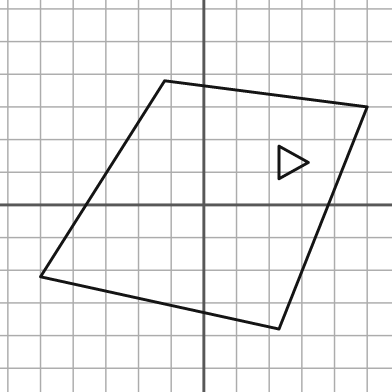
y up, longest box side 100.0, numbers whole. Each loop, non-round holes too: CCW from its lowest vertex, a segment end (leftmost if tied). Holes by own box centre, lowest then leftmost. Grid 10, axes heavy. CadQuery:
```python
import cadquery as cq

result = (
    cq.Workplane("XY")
    .moveTo(23.0, -38.0)
    .lineTo(50.0, 30.0)
    .lineTo(-12.0, 38.0)
    .lineTo(-50.0, -22.0)
    .close()
    .moveTo(23.0, 8.0)
    .lineTo(32.0, 13.0)
    .lineTo(23.0, 18.0)
    .close()
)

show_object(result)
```